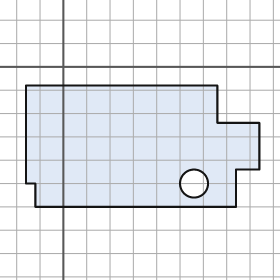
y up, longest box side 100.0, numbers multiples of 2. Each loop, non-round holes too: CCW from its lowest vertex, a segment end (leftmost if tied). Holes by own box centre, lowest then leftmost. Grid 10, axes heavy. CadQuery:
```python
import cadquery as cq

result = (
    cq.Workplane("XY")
    .moveTo(-12.0, -60.0)
    .lineTo(74.0, -60.0)
    .lineTo(74.0, -44.0)
    .lineTo(84.0, -44.0)
    .lineTo(84.0, -24.0)
    .lineTo(66.0, -24.0)
    .lineTo(66.0, -8.0)
    .lineTo(-16.0, -8.0)
    .lineTo(-16.0, -50.0)
    .lineTo(-12.0, -50.0)
    .close()
    .moveTo(56.0, -50.0)
    .circle(6.0)
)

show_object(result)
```